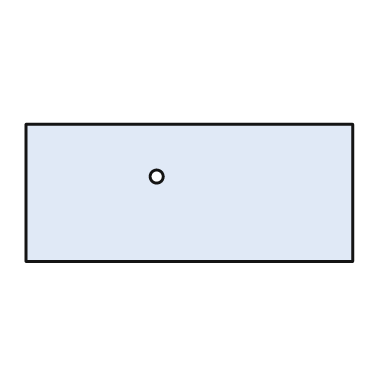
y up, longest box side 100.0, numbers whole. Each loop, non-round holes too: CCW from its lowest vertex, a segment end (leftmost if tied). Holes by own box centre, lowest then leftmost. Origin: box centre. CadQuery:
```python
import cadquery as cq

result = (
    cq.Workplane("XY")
    .moveTo(-50.0, -21.0)
    .lineTo(50.0, -21.0)
    .lineTo(50.0, 21.0)
    .lineTo(-50.0, 21.0)
    .close()
    .moveTo(-10.0, 5.0)
    .circle(2.0)
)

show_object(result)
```